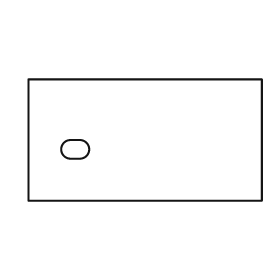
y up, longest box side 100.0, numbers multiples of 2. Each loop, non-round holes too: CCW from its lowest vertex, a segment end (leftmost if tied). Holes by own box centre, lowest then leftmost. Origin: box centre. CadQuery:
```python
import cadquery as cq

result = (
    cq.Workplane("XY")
    .moveTo(-50.0, -26.0)
    .lineTo(50.0, -26.0)
    .lineTo(50.0, 26.0)
    .lineTo(-50.0, 26.0)
    .close()
    .moveTo(-32.0, -8.0)
    .lineTo(-28.0, -8.0)
    .threePointArc((-24.0, -4.0), (-28.0, 0.0))
    .lineTo(-32.0, 0.0)
    .threePointArc((-36.0, -4.0), (-32.0, -8.0))
    .close()
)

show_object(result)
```